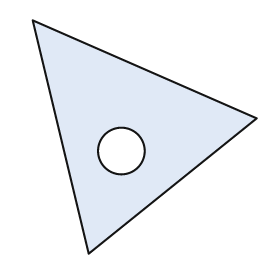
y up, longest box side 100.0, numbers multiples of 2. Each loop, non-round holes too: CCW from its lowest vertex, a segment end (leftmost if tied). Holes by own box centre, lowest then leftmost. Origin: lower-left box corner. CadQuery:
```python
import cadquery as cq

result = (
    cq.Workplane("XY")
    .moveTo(24.0, 0.0)
    .lineTo(96.0, 58.0)
    .lineTo(0.0, 100.0)
    .close()
    .moveTo(38.0, 44.0)
    .circle(10.0)
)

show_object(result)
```